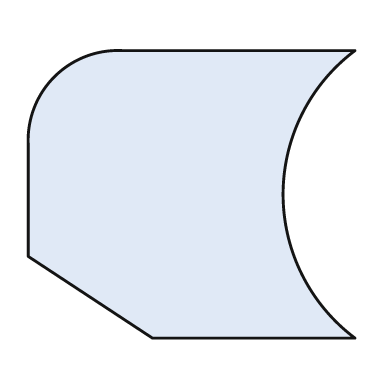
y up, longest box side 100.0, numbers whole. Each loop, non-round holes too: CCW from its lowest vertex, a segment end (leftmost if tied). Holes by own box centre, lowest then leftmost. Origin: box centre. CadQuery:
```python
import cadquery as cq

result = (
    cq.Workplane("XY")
    .moveTo(-12.0, -44.0)
    .lineTo(50.0, -44.0)
    .threePointArc((28.0, 0.0), (50.0, 44.0))
    .lineTo(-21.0, 44.0)
    .threePointArc((-42.0, 36.0), (-50.0, 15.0))
    .lineTo(-50.0, -19.0)
    .close()
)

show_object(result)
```